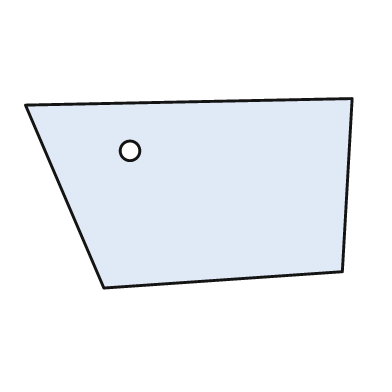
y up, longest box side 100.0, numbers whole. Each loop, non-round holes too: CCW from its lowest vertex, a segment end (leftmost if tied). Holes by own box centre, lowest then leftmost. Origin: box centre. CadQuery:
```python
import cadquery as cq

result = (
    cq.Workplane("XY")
    .moveTo(-26.0, -29.0)
    .lineTo(47.0, -24.0)
    .lineTo(50.0, 29.0)
    .lineTo(-50.0, 27.0)
    .close()
    .moveTo(-18.0, 13.0)
    .circle(3.0)
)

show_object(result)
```